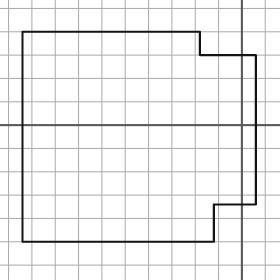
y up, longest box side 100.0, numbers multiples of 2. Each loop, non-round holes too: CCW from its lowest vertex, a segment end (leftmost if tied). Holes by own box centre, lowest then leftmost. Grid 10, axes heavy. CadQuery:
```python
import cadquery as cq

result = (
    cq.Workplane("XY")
    .moveTo(-94.0, -50.0)
    .lineTo(-12.0, -50.0)
    .lineTo(-12.0, -34.0)
    .lineTo(6.0, -34.0)
    .lineTo(6.0, 30.0)
    .lineTo(-18.0, 30.0)
    .lineTo(-18.0, 40.0)
    .lineTo(-94.0, 40.0)
    .close()
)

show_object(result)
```